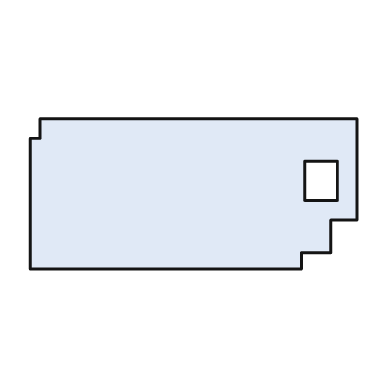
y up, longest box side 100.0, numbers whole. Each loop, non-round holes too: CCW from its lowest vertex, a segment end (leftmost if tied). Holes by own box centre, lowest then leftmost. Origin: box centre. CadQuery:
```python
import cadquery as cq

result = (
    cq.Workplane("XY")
    .moveTo(-50.0, -23.0)
    .lineTo(33.0, -23.0)
    .lineTo(33.0, -18.0)
    .lineTo(42.0, -18.0)
    .lineTo(42.0, -8.0)
    .lineTo(50.0, -8.0)
    .lineTo(50.0, 23.0)
    .lineTo(-47.0, 23.0)
    .lineTo(-47.0, 17.0)
    .lineTo(-50.0, 17.0)
    .close()
    .moveTo(34.0, -2.0)
    .lineTo(44.0, -2.0)
    .lineTo(44.0, 10.0)
    .lineTo(34.0, 10.0)
    .close()
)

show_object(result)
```